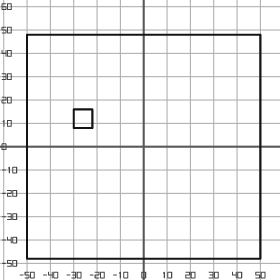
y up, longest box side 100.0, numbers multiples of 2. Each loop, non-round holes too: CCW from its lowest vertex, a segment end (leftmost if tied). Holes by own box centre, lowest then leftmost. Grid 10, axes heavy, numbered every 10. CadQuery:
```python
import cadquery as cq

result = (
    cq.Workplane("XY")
    .moveTo(-50.0, -48.0)
    .lineTo(50.0, -48.0)
    .lineTo(50.0, 48.0)
    .lineTo(-50.0, 48.0)
    .close()
    .moveTo(-30.0, 8.0)
    .lineTo(-22.0, 8.0)
    .lineTo(-22.0, 16.0)
    .lineTo(-30.0, 16.0)
    .close()
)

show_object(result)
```